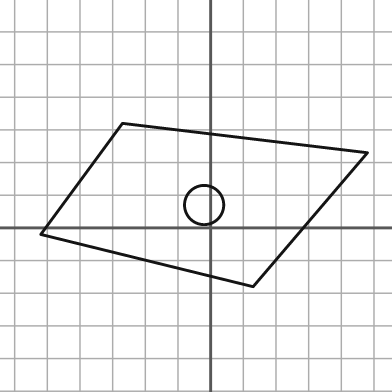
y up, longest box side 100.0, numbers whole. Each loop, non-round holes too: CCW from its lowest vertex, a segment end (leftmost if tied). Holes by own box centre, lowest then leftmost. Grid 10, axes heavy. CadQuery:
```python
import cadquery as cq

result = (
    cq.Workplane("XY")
    .moveTo(13.0, -18.0)
    .lineTo(48.0, 23.0)
    .lineTo(-27.0, 32.0)
    .lineTo(-52.0, -2.0)
    .close()
    .moveTo(-2.0, 7.0)
    .circle(6.0)
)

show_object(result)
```